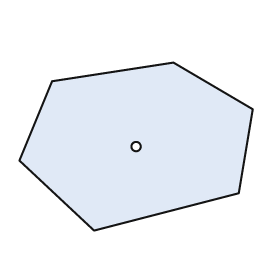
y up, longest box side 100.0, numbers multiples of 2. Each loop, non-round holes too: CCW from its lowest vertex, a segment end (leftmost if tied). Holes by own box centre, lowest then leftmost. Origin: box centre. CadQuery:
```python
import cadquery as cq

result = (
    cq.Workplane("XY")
    .moveTo(-18.0, -36.0)
    .lineTo(44.0, -20.0)
    .lineTo(50.0, 16.0)
    .lineTo(16.0, 36.0)
    .lineTo(-36.0, 28.0)
    .lineTo(-50.0, -6.0)
    .close()
    .moveTo(0.0, 0.0)
    .circle(2.0)
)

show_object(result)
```